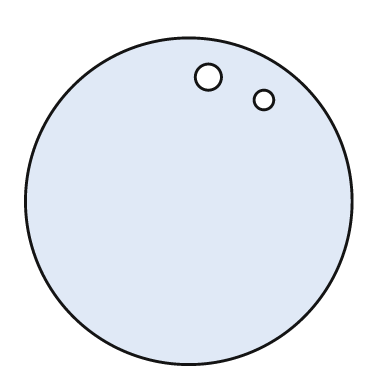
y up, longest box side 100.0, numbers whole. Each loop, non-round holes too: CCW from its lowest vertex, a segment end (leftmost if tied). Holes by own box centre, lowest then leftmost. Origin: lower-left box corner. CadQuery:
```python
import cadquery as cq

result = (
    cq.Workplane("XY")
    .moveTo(50.0, 50.0)
    .circle(50.0)
    .moveTo(73.0, 81.0)
    .circle(3.0)
    .moveTo(56.0, 88.0)
    .circle(4.0)
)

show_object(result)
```